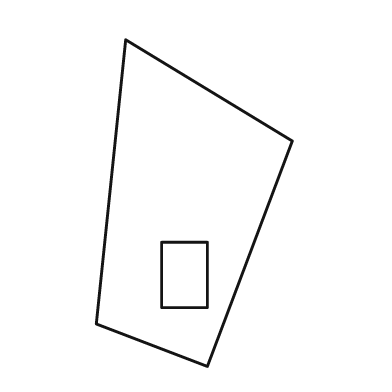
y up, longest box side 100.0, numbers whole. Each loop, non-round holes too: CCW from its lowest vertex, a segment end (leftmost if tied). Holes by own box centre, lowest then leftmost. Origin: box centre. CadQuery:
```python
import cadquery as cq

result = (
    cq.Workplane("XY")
    .moveTo(4.0, -50.0)
    .lineTo(30.0, 19.0)
    .lineTo(-21.0, 50.0)
    .lineTo(-30.0, -37.0)
    .close()
    .moveTo(-10.0, -32.0)
    .lineTo(4.0, -32.0)
    .lineTo(4.0, -12.0)
    .lineTo(-10.0, -12.0)
    .close()
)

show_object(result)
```